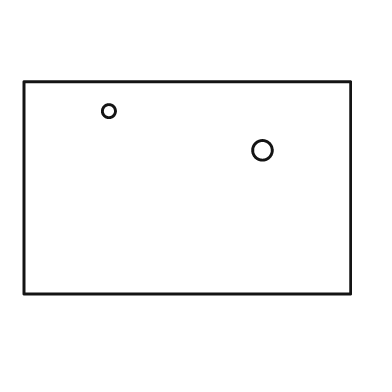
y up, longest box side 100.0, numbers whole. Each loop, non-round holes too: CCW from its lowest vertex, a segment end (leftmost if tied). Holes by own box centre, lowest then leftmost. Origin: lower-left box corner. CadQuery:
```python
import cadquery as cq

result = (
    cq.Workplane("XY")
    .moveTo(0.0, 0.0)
    .lineTo(100.0, 0.0)
    .lineTo(100.0, 65.0)
    .lineTo(0.0, 65.0)
    .close()
    .moveTo(73.0, 44.0)
    .circle(3.0)
    .moveTo(26.0, 56.0)
    .circle(2.0)
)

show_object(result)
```